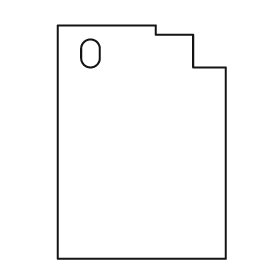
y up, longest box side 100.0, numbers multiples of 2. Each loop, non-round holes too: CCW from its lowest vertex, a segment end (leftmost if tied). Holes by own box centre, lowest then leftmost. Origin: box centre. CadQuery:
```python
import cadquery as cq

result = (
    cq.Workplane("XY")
    .moveTo(-36.0, -50.0)
    .lineTo(36.0, -50.0)
    .lineTo(36.0, 32.0)
    .lineTo(22.0, 32.0)
    .lineTo(22.0, 46.0)
    .lineTo(6.0, 46.0)
    .lineTo(6.0, 50.0)
    .lineTo(-36.0, 50.0)
    .close()
    .moveTo(-26.0, 36.0)
    .threePointArc((-22.0, 32.0), (-18.0, 36.0))
    .lineTo(-18.0, 40.0)
    .threePointArc((-22.0, 44.0), (-26.0, 40.0))
    .close()
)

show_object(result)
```